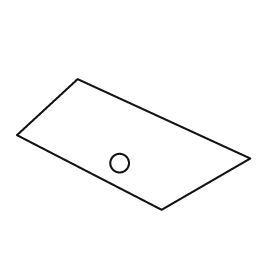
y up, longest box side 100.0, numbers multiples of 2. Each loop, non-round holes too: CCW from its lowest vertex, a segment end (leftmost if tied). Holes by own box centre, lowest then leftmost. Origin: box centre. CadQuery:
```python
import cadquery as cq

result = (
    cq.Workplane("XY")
    .moveTo(12.0, -28.0)
    .lineTo(50.0, -6.0)
    .lineTo(-24.0, 28.0)
    .lineTo(-50.0, 4.0)
    .close()
    .moveTo(-6.0, -8.0)
    .circle(4.0)
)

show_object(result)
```